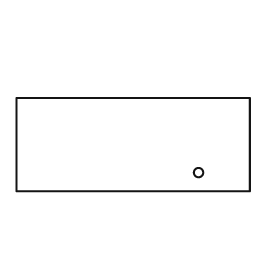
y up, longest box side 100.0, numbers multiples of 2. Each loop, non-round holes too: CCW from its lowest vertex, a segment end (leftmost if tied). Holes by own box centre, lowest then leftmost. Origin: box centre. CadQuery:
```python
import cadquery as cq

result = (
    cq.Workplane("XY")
    .moveTo(-50.0, -20.0)
    .lineTo(50.0, -20.0)
    .lineTo(50.0, 20.0)
    .lineTo(-50.0, 20.0)
    .close()
    .moveTo(28.0, -12.0)
    .circle(2.0)
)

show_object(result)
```